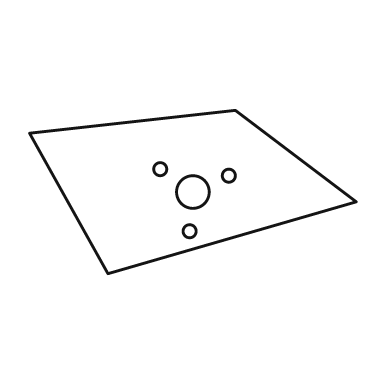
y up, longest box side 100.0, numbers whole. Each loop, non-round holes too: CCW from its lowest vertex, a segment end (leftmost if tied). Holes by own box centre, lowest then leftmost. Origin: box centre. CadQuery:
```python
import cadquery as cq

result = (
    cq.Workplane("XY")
    .moveTo(-26.0, -25.0)
    .lineTo(50.0, -3.0)
    .lineTo(13.0, 25.0)
    .lineTo(-50.0, 18.0)
    .close()
    .moveTo(-1.0, -12.0)
    .circle(2.0)
    .moveTo(0.0, 0.0)
    .circle(5.0)
    .moveTo(11.0, 5.0)
    .circle(2.0)
    .moveTo(-10.0, 7.0)
    .circle(2.0)
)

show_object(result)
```